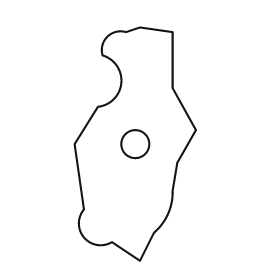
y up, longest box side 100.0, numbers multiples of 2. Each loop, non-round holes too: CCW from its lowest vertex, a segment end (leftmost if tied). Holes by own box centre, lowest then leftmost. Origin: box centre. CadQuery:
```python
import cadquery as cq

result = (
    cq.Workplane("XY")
    .moveTo(2.0, -50.0)
    .lineTo(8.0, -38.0)
    .threePointArc((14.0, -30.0), (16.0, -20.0))
    .lineTo(18.0, -8.0)
    .lineTo(26.0, 6.0)
    .lineTo(16.0, 24.0)
    .lineTo(16.0, 48.0)
    .lineTo(2.0, 50.0)
    .lineTo(-4.0, 48.0)
    .threePointArc((-12.0, 46.0), (-14.0, 38.0))
    .threePointArc((-6.0, 26.0), (-16.0, 16.0))
    .lineTo(-26.0, 0.0)
    .lineTo(-22.0, -28.0)
    .threePointArc((-22.0, -40.0), (-10.0, -42.0))
    .close()
    .moveTo(0.0, 0.0)
    .circle(6.0)
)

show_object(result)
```